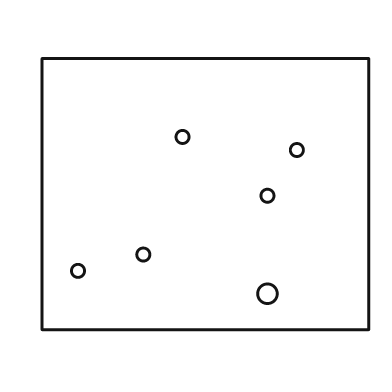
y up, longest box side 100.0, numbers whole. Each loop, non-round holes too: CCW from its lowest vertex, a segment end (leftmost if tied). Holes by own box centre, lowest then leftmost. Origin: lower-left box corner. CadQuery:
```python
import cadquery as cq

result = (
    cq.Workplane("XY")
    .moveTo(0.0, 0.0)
    .lineTo(100.0, 0.0)
    .lineTo(100.0, 83.0)
    .lineTo(0.0, 83.0)
    .close()
    .moveTo(69.0, 11.0)
    .circle(3.0)
    .moveTo(11.0, 18.0)
    .circle(2.0)
    .moveTo(31.0, 23.0)
    .circle(2.0)
    .moveTo(69.0, 41.0)
    .circle(2.0)
    .moveTo(78.0, 55.0)
    .circle(2.0)
    .moveTo(43.0, 59.0)
    .circle(2.0)
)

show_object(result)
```